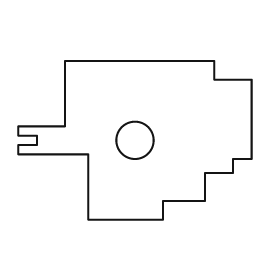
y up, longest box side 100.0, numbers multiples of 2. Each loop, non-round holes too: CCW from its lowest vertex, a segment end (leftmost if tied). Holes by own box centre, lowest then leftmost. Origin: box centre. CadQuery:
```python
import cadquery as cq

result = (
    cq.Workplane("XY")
    .moveTo(-20.0, -34.0)
    .lineTo(12.0, -34.0)
    .lineTo(12.0, -26.0)
    .lineTo(30.0, -26.0)
    .lineTo(30.0, -14.0)
    .lineTo(42.0, -14.0)
    .lineTo(42.0, -8.0)
    .lineTo(50.0, -8.0)
    .lineTo(50.0, 26.0)
    .lineTo(34.0, 26.0)
    .lineTo(34.0, 34.0)
    .lineTo(-30.0, 34.0)
    .lineTo(-30.0, 6.0)
    .lineTo(-50.0, 6.0)
    .lineTo(-50.0, 2.0)
    .lineTo(-42.0, 2.0)
    .lineTo(-42.0, -2.0)
    .lineTo(-50.0, -2.0)
    .lineTo(-50.0, -6.0)
    .lineTo(-20.0, -6.0)
    .close()
    .moveTo(0.0, 0.0)
    .circle(8.0)
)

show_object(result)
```